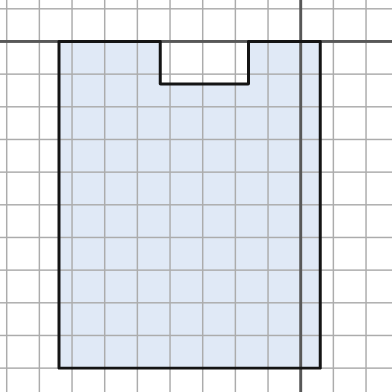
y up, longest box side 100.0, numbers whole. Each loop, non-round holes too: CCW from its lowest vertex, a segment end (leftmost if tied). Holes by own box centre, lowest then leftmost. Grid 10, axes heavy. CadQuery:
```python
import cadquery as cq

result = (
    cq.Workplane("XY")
    .moveTo(-74.0, -100.0)
    .lineTo(6.0, -100.0)
    .lineTo(6.0, 0.0)
    .lineTo(-16.0, 0.0)
    .lineTo(-16.0, -13.0)
    .lineTo(-43.0, -13.0)
    .lineTo(-43.0, 0.0)
    .lineTo(-74.0, 0.0)
    .close()
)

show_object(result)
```